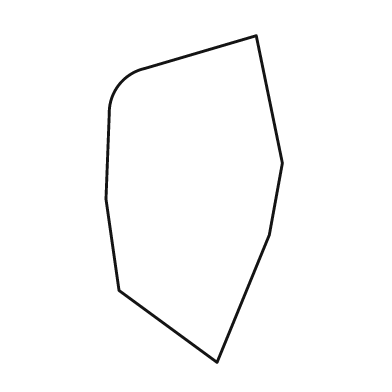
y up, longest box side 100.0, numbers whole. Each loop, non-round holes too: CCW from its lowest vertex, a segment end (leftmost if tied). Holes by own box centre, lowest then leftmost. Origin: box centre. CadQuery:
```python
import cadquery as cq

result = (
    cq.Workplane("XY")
    .moveTo(7.0, -50.0)
    .lineTo(23.0, -11.0)
    .lineTo(27.0, 11.0)
    .lineTo(19.0, 50.0)
    .lineTo(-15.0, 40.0)
    .threePointArc((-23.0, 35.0), (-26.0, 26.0))
    .lineTo(-27.0, 0.0)
    .lineTo(-23.0, -28.0)
    .close()
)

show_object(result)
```